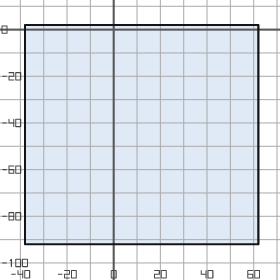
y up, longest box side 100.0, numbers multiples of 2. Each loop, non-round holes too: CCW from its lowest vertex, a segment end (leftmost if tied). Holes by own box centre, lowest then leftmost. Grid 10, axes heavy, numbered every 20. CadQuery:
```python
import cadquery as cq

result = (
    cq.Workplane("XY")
    .moveTo(-38.0, -92.0)
    .lineTo(62.0, -92.0)
    .lineTo(62.0, 2.0)
    .lineTo(-38.0, 2.0)
    .close()
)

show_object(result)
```